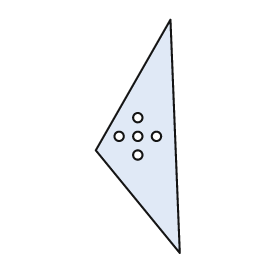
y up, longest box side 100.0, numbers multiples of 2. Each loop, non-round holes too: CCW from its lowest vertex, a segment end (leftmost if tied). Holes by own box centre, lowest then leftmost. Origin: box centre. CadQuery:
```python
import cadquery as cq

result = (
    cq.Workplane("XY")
    .moveTo(18.0, -50.0)
    .lineTo(14.0, 50.0)
    .lineTo(-18.0, -6.0)
    .close()
    .moveTo(0.0, -8.0)
    .circle(2.0)
    .moveTo(-8.0, 0.0)
    .circle(2.0)
    .moveTo(0.0, 0.0)
    .circle(2.0)
    .moveTo(8.0, 0.0)
    .circle(2.0)
    .moveTo(0.0, 8.0)
    .circle(2.0)
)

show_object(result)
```